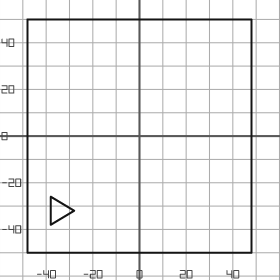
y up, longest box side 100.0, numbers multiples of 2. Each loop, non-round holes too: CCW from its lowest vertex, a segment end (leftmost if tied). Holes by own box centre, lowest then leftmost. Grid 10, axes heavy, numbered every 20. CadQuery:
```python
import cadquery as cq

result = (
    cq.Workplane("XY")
    .moveTo(-48.0, -50.0)
    .lineTo(48.0, -50.0)
    .lineTo(48.0, 50.0)
    .lineTo(-48.0, 50.0)
    .close()
    .moveTo(-38.0, -38.0)
    .lineTo(-28.0, -32.0)
    .lineTo(-38.0, -26.0)
    .close()
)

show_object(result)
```